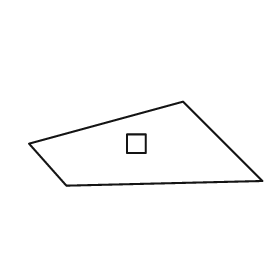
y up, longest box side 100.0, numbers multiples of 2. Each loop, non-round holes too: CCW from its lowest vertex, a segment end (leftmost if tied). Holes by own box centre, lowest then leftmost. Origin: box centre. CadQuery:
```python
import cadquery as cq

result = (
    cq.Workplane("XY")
    .moveTo(-34.0, -18.0)
    .lineTo(50.0, -16.0)
    .lineTo(16.0, 18.0)
    .lineTo(-50.0, 0.0)
    .close()
    .moveTo(-8.0, -4.0)
    .lineTo(0.0, -4.0)
    .lineTo(0.0, 4.0)
    .lineTo(-8.0, 4.0)
    .close()
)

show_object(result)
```